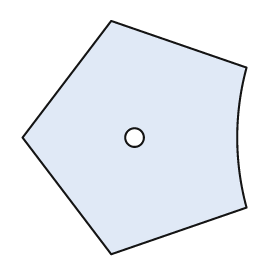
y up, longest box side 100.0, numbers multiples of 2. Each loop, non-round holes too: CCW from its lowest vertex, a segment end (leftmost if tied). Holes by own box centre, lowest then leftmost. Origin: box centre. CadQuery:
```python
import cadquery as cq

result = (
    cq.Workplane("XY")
    .moveTo(-10.0, -50.0)
    .lineTo(48.0, -30.0)
    .threePointArc((44.0, 0.0), (48.0, 30.0))
    .lineTo(-10.0, 50.0)
    .lineTo(-48.0, 0.0)
    .close()
    .moveTo(0.0, 0.0)
    .circle(4.0)
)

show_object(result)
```